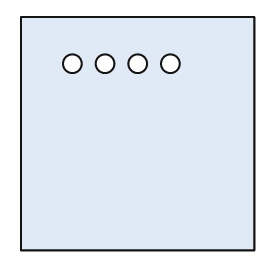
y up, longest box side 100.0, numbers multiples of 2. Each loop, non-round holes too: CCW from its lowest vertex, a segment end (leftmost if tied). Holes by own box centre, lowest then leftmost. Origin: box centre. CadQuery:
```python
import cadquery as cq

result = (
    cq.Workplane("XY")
    .moveTo(-50.0, -50.0)
    .lineTo(50.0, -50.0)
    .lineTo(50.0, 50.0)
    .lineTo(-50.0, 50.0)
    .close()
    .moveTo(-28.0, 30.0)
    .circle(4.0)
    .moveTo(-14.0, 30.0)
    .circle(4.0)
    .moveTo(0.0, 30.0)
    .circle(4.0)
    .moveTo(14.0, 30.0)
    .circle(4.0)
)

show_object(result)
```